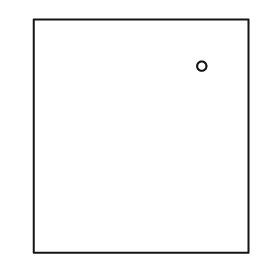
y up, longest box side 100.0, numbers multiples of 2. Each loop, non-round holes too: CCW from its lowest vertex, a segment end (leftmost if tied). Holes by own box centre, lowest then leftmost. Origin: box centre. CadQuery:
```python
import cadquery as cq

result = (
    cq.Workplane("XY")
    .moveTo(-46.0, -50.0)
    .lineTo(46.0, -50.0)
    .lineTo(46.0, 50.0)
    .lineTo(-46.0, 50.0)
    .close()
    .moveTo(26.0, 30.0)
    .circle(2.0)
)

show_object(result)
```